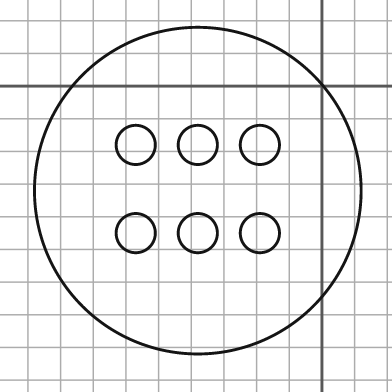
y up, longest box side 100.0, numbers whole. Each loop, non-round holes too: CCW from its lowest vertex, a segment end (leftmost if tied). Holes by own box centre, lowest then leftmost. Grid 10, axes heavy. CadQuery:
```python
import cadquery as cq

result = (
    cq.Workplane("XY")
    .moveTo(-38.0, -32.0)
    .circle(50.0)
    .moveTo(-57.0, -45.0)
    .circle(6.0)
    .moveTo(-38.0, -45.0)
    .circle(6.0)
    .moveTo(-19.0, -45.0)
    .circle(6.0)
    .moveTo(-57.0, -18.0)
    .circle(6.0)
    .moveTo(-38.0, -18.0)
    .circle(6.0)
    .moveTo(-19.0, -18.0)
    .circle(6.0)
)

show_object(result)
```